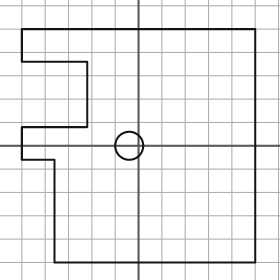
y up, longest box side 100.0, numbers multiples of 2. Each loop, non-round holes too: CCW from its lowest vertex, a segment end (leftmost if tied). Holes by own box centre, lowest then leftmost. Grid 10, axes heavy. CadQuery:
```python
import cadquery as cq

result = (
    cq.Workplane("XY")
    .moveTo(-36.0, -50.0)
    .lineTo(50.0, -50.0)
    .lineTo(50.0, 50.0)
    .lineTo(-50.0, 50.0)
    .lineTo(-50.0, 36.0)
    .lineTo(-22.0, 36.0)
    .lineTo(-22.0, 8.0)
    .lineTo(-50.0, 8.0)
    .lineTo(-50.0, -6.0)
    .lineTo(-36.0, -6.0)
    .close()
    .moveTo(-4.0, 0.0)
    .circle(6.0)
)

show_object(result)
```